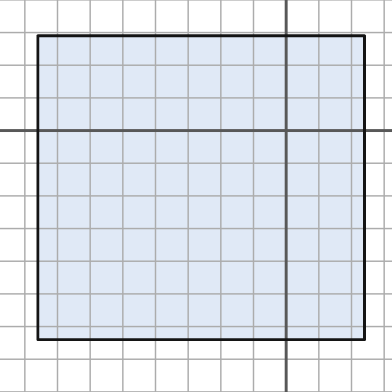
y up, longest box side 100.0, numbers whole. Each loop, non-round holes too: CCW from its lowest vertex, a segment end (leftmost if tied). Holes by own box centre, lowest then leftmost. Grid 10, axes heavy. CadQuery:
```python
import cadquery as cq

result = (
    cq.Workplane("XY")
    .moveTo(-76.0, -64.0)
    .lineTo(24.0, -64.0)
    .lineTo(24.0, 29.0)
    .lineTo(-76.0, 29.0)
    .close()
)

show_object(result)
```